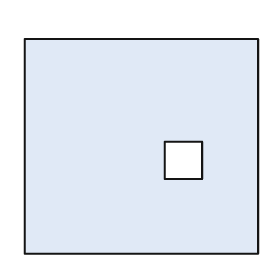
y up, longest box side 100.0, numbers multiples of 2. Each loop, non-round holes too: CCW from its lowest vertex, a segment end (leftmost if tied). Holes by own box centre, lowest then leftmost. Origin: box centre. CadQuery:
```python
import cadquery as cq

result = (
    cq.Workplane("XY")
    .moveTo(-50.0, -46.0)
    .lineTo(50.0, -46.0)
    .lineTo(50.0, 46.0)
    .lineTo(-50.0, 46.0)
    .close()
    .moveTo(10.0, -14.0)
    .lineTo(26.0, -14.0)
    .lineTo(26.0, 2.0)
    .lineTo(10.0, 2.0)
    .close()
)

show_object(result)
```